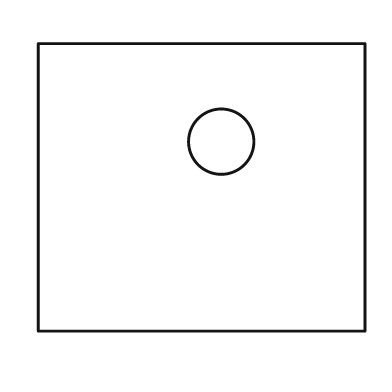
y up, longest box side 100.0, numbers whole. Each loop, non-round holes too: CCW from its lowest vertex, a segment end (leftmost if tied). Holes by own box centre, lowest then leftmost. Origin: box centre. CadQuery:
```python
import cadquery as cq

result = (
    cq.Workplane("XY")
    .moveTo(-50.0, -44.0)
    .lineTo(50.0, -44.0)
    .lineTo(50.0, 44.0)
    .lineTo(-50.0, 44.0)
    .close()
    .moveTo(6.0, 14.0)
    .circle(10.0)
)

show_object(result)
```